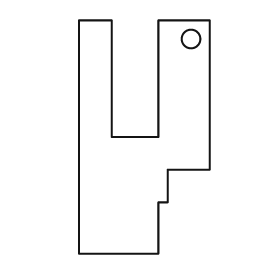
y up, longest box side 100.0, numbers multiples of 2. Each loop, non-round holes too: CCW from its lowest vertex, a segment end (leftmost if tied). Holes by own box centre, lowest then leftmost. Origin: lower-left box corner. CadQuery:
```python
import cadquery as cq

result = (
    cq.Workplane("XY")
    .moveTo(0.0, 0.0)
    .lineTo(34.0, 0.0)
    .lineTo(34.0, 22.0)
    .lineTo(38.0, 22.0)
    .lineTo(38.0, 36.0)
    .lineTo(56.0, 36.0)
    .lineTo(56.0, 100.0)
    .lineTo(34.0, 100.0)
    .lineTo(34.0, 50.0)
    .lineTo(14.0, 50.0)
    .lineTo(14.0, 100.0)
    .lineTo(0.0, 100.0)
    .close()
    .moveTo(48.0, 92.0)
    .circle(4.0)
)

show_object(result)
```